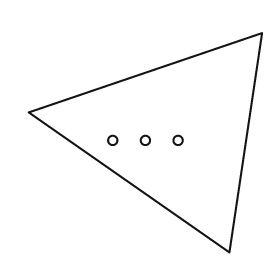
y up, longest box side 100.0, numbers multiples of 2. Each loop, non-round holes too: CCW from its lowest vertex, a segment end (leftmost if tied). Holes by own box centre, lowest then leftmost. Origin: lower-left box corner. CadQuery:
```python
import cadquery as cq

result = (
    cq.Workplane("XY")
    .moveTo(86.0, 0.0)
    .lineTo(100.0, 94.0)
    .lineTo(0.0, 60.0)
    .close()
    .moveTo(36.0, 48.0)
    .circle(2.0)
    .moveTo(50.0, 48.0)
    .circle(2.0)
    .moveTo(64.0, 48.0)
    .circle(2.0)
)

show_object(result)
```